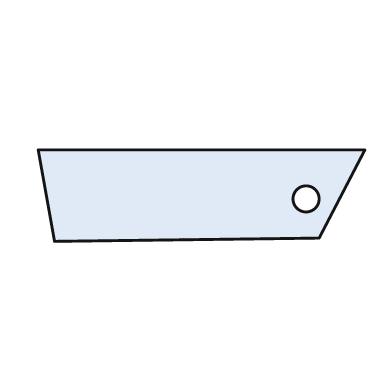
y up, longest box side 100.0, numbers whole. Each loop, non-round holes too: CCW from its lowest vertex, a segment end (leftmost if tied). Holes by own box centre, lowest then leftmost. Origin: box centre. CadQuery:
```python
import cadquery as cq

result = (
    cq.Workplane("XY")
    .moveTo(-45.0, -14.0)
    .lineTo(36.0, -13.0)
    .lineTo(50.0, 14.0)
    .lineTo(-50.0, 14.0)
    .close()
    .moveTo(32.0, -1.0)
    .circle(4.0)
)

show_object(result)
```